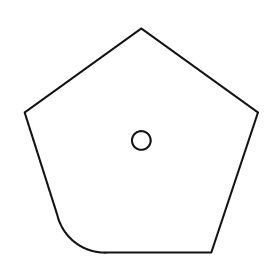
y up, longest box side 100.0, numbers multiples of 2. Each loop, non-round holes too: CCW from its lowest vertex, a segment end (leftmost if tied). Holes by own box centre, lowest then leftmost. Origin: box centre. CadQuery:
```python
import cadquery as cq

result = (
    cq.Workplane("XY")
    .moveTo(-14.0, -48.0)
    .lineTo(30.0, -48.0)
    .lineTo(50.0, 12.0)
    .lineTo(0.0, 48.0)
    .lineTo(-50.0, 12.0)
    .lineTo(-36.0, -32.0)
    .threePointArc((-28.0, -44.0), (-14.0, -48.0))
    .close()
    .moveTo(0.0, 0.0)
    .circle(4.0)
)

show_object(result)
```